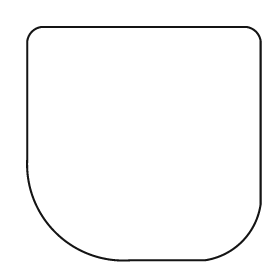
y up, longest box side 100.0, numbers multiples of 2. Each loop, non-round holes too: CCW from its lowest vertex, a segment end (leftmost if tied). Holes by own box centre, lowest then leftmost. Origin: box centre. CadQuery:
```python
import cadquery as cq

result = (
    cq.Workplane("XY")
    .moveTo(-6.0, -50.0)
    .lineTo(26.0, -50.0)
    .threePointArc((42.0, -42.0), (50.0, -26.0))
    .lineTo(50.0, 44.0)
    .threePointArc((48.0, 48.0), (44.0, 50.0))
    .lineTo(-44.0, 50.0)
    .threePointArc((-48.0, 48.0), (-50.0, 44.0))
    .lineTo(-50.0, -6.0)
    .threePointArc((-38.0, -38.0), (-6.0, -50.0))
    .close()
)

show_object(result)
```